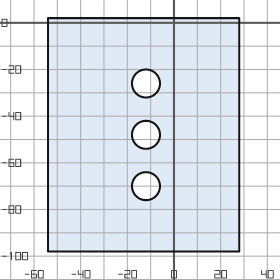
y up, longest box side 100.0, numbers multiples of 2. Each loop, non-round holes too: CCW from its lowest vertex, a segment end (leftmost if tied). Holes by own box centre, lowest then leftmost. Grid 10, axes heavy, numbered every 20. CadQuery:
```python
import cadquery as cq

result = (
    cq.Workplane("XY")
    .moveTo(-54.0, -98.0)
    .lineTo(28.0, -98.0)
    .lineTo(28.0, 2.0)
    .lineTo(-54.0, 2.0)
    .close()
    .moveTo(-12.0, -70.0)
    .circle(6.0)
    .moveTo(-12.0, -48.0)
    .circle(6.0)
    .moveTo(-12.0, -26.0)
    .circle(6.0)
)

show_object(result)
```